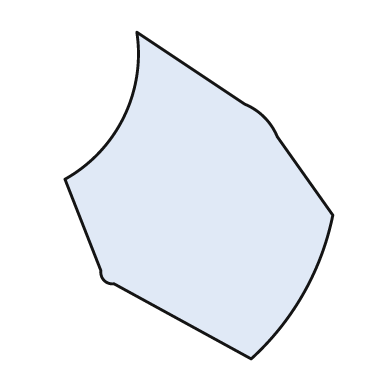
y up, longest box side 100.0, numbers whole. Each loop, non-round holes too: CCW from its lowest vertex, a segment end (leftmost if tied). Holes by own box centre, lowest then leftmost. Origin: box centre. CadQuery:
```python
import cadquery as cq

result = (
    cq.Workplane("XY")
    .moveTo(16.0, -50.0)
    .threePointArc((32.0, -30.0), (41.0, -6.0))
    .lineTo(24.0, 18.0)
    .threePointArc((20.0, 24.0), (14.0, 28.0))
    .lineTo(-19.0, 50.0)
    .threePointArc((-23.0, 24.0), (-41.0, 5.0))
    .lineTo(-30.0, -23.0)
    .threePointArc((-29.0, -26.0), (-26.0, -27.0))
    .close()
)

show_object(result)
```